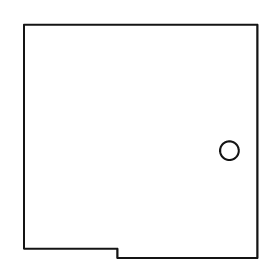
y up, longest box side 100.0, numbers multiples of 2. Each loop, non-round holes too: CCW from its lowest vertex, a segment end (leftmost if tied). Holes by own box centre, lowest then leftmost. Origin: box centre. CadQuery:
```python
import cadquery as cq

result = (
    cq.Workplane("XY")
    .moveTo(-10.0, -50.0)
    .lineTo(50.0, -50.0)
    .lineTo(50.0, 50.0)
    .lineTo(-50.0, 50.0)
    .lineTo(-50.0, -46.0)
    .lineTo(-10.0, -46.0)
    .close()
    .moveTo(38.0, -4.0)
    .circle(4.0)
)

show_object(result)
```